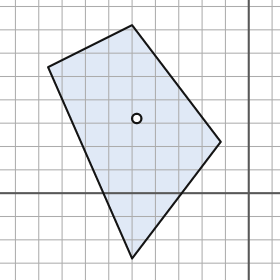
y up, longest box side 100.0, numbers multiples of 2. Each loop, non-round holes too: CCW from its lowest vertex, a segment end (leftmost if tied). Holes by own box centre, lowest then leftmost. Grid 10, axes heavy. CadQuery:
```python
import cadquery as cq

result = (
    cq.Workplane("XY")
    .moveTo(-50.0, -28.0)
    .lineTo(-12.0, 22.0)
    .lineTo(-50.0, 72.0)
    .lineTo(-86.0, 54.0)
    .close()
    .moveTo(-48.0, 32.0)
    .circle(2.0)
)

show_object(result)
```